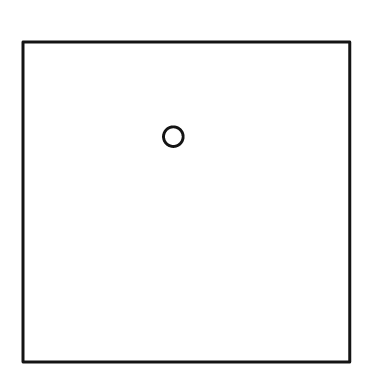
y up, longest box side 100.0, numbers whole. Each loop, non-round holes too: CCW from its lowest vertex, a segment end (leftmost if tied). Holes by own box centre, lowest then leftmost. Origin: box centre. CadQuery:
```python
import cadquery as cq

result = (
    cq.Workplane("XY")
    .moveTo(-50.0, -49.0)
    .lineTo(50.0, -49.0)
    .lineTo(50.0, 49.0)
    .lineTo(-50.0, 49.0)
    .close()
    .moveTo(-4.0, 20.0)
    .circle(3.0)
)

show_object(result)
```